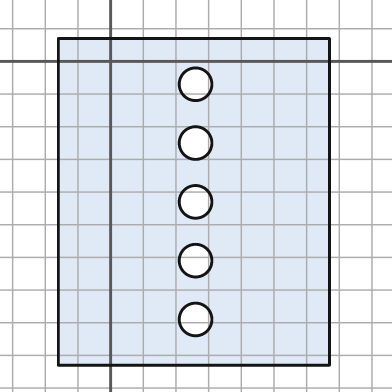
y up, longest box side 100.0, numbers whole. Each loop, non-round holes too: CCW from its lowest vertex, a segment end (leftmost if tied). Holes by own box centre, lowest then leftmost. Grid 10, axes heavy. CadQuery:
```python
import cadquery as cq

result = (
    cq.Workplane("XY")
    .moveTo(-16.0, -93.0)
    .lineTo(67.0, -93.0)
    .lineTo(67.0, 7.0)
    .lineTo(-16.0, 7.0)
    .close()
    .moveTo(26.0, -79.0)
    .circle(5.0)
    .moveTo(26.0, -61.0)
    .circle(5.0)
    .moveTo(26.0, -43.0)
    .circle(5.0)
    .moveTo(26.0, -25.0)
    .circle(5.0)
    .moveTo(26.0, -7.0)
    .circle(5.0)
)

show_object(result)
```